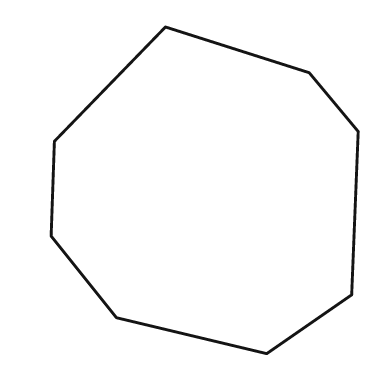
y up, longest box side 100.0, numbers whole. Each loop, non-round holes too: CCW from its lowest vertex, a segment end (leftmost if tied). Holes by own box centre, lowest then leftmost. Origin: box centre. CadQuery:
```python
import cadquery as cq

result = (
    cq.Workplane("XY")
    .moveTo(19.0, -50.0)
    .lineTo(45.0, -32.0)
    .lineTo(47.0, 18.0)
    .lineTo(32.0, 36.0)
    .lineTo(-12.0, 50.0)
    .lineTo(-46.0, 15.0)
    .lineTo(-47.0, -14.0)
    .lineTo(-27.0, -39.0)
    .close()
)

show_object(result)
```